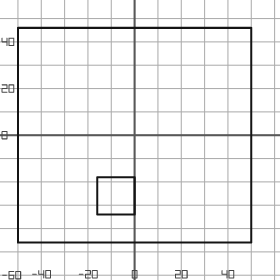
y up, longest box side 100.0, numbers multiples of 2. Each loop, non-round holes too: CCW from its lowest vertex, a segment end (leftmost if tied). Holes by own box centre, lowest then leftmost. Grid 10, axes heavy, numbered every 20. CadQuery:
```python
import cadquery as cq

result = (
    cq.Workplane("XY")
    .moveTo(-50.0, -46.0)
    .lineTo(50.0, -46.0)
    .lineTo(50.0, 46.0)
    .lineTo(-50.0, 46.0)
    .close()
    .moveTo(-16.0, -34.0)
    .lineTo(0.0, -34.0)
    .lineTo(0.0, -18.0)
    .lineTo(-16.0, -18.0)
    .close()
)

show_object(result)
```